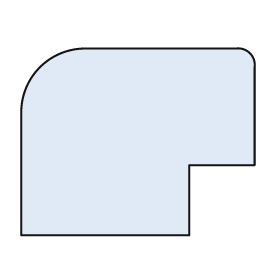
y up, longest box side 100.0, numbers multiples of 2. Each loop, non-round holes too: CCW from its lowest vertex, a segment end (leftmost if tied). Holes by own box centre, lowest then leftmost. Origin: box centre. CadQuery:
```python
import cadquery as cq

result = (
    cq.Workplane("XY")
    .moveTo(-50.0, -40.0)
    .lineTo(22.0, -40.0)
    .lineTo(22.0, -10.0)
    .lineTo(50.0, -10.0)
    .lineTo(50.0, 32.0)
    .threePointArc((48.0, 38.0), (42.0, 40.0))
    .lineTo(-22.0, 40.0)
    .threePointArc((-42.0, 32.0), (-50.0, 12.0))
    .close()
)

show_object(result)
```